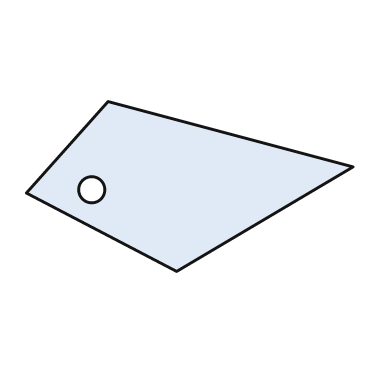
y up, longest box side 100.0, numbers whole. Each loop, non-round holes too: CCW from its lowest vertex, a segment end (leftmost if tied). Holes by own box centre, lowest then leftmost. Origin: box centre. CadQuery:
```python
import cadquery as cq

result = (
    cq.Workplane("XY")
    .moveTo(-4.0, -26.0)
    .lineTo(50.0, 6.0)
    .lineTo(-25.0, 26.0)
    .lineTo(-50.0, -2.0)
    .close()
    .moveTo(-30.0, -1.0)
    .circle(4.0)
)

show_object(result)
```